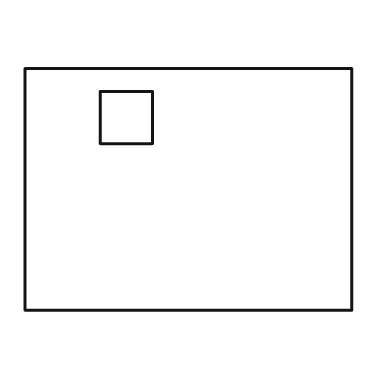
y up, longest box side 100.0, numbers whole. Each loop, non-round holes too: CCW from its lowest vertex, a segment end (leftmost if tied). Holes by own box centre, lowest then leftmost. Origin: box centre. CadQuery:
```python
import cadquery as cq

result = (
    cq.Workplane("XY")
    .moveTo(-50.0, -37.0)
    .lineTo(50.0, -37.0)
    .lineTo(50.0, 37.0)
    .lineTo(-50.0, 37.0)
    .close()
    .moveTo(-27.0, 14.0)
    .lineTo(-11.0, 14.0)
    .lineTo(-11.0, 30.0)
    .lineTo(-27.0, 30.0)
    .close()
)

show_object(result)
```